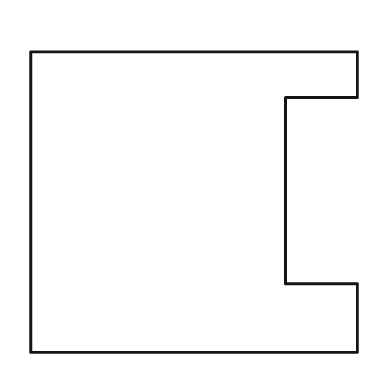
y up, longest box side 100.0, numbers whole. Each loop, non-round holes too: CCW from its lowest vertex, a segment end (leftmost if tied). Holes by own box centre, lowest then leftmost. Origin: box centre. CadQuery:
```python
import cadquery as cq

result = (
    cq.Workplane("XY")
    .moveTo(-50.0, -46.0)
    .lineTo(50.0, -46.0)
    .lineTo(50.0, -25.0)
    .lineTo(28.0, -25.0)
    .lineTo(28.0, 32.0)
    .lineTo(50.0, 32.0)
    .lineTo(50.0, 46.0)
    .lineTo(-50.0, 46.0)
    .close()
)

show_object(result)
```